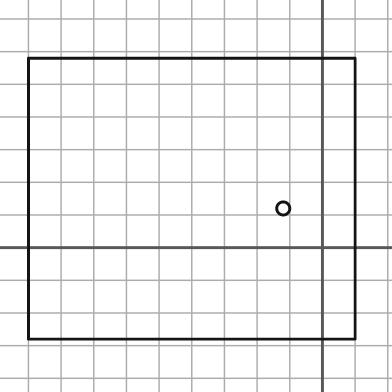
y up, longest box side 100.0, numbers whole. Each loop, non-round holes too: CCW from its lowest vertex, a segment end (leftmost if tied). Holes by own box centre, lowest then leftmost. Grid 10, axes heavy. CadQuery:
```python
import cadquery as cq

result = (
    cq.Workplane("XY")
    .moveTo(-90.0, -28.0)
    .lineTo(10.0, -28.0)
    .lineTo(10.0, 58.0)
    .lineTo(-90.0, 58.0)
    .close()
    .moveTo(-12.0, 12.0)
    .circle(2.0)
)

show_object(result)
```